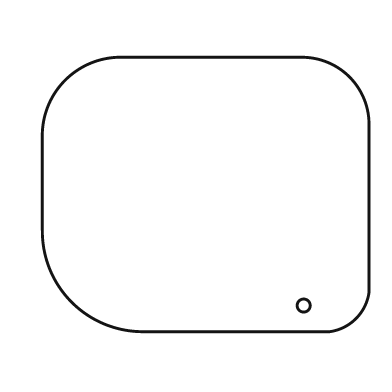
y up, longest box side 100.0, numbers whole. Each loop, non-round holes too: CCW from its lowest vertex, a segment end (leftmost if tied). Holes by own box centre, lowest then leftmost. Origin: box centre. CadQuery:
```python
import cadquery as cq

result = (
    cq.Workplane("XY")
    .moveTo(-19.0, -42.0)
    .lineTo(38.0, -42.0)
    .threePointArc((46.0, -38.0), (50.0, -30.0))
    .lineTo(50.0, 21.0)
    .threePointArc((44.0, 36.0), (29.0, 42.0))
    .lineTo(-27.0, 42.0)
    .threePointArc((-43.0, 35.0), (-50.0, 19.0))
    .lineTo(-50.0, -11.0)
    .threePointArc((-41.0, -33.0), (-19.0, -42.0))
    .close()
    .moveTo(30.0, -34.0)
    .circle(2.0)
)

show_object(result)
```